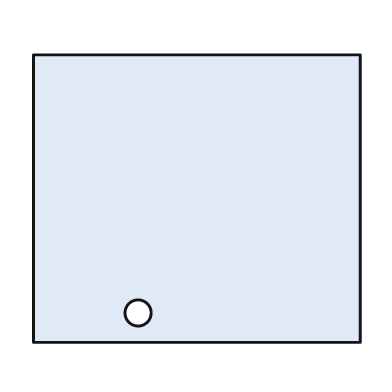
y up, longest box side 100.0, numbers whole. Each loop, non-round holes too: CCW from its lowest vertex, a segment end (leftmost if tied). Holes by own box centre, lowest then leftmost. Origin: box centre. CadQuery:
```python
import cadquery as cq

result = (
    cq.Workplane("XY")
    .moveTo(-50.0, -44.0)
    .lineTo(50.0, -44.0)
    .lineTo(50.0, 44.0)
    .lineTo(-50.0, 44.0)
    .close()
    .moveTo(-18.0, -35.0)
    .circle(4.0)
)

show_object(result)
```